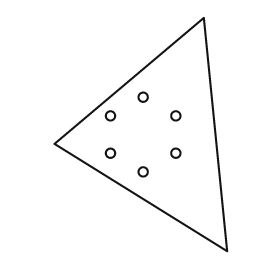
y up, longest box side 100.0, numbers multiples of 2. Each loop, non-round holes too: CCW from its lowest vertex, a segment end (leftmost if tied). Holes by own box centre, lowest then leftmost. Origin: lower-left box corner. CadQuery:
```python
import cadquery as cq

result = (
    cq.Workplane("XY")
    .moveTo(74.0, 0.0)
    .lineTo(64.0, 100.0)
    .lineTo(0.0, 46.0)
    .close()
    .moveTo(38.0, 34.0)
    .circle(2.0)
    .moveTo(24.0, 42.0)
    .circle(2.0)
    .moveTo(52.0, 42.0)
    .circle(2.0)
    .moveTo(24.0, 58.0)
    .circle(2.0)
    .moveTo(52.0, 58.0)
    .circle(2.0)
    .moveTo(38.0, 66.0)
    .circle(2.0)
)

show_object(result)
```